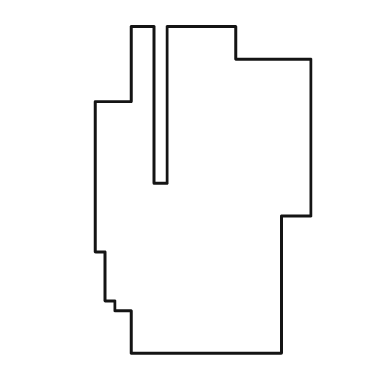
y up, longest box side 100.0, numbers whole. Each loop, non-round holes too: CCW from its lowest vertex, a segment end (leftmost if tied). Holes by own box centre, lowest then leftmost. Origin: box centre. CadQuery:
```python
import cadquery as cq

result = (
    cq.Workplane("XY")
    .moveTo(-22.0, -50.0)
    .lineTo(24.0, -50.0)
    .lineTo(24.0, -8.0)
    .lineTo(33.0, -8.0)
    .lineTo(33.0, 40.0)
    .lineTo(10.0, 40.0)
    .lineTo(10.0, 50.0)
    .lineTo(-11.0, 50.0)
    .lineTo(-11.0, 2.0)
    .lineTo(-15.0, 2.0)
    .lineTo(-15.0, 50.0)
    .lineTo(-22.0, 50.0)
    .lineTo(-22.0, 27.0)
    .lineTo(-33.0, 27.0)
    .lineTo(-33.0, -19.0)
    .lineTo(-30.0, -19.0)
    .lineTo(-30.0, -34.0)
    .lineTo(-27.0, -34.0)
    .lineTo(-27.0, -37.0)
    .lineTo(-22.0, -37.0)
    .close()
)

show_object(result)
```